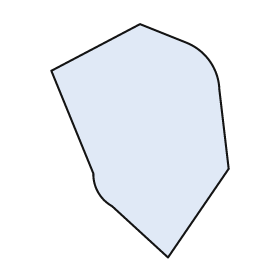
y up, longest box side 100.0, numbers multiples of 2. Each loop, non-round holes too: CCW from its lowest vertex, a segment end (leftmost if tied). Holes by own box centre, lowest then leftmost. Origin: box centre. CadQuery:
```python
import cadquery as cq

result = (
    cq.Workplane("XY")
    .moveTo(12.0, -50.0)
    .lineTo(38.0, -12.0)
    .lineTo(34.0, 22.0)
    .threePointArc((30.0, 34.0), (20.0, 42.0))
    .lineTo(0.0, 50.0)
    .lineTo(-38.0, 30.0)
    .lineTo(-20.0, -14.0)
    .threePointArc((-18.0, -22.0), (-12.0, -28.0))
    .close()
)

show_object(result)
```